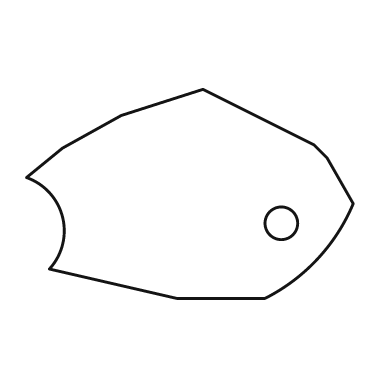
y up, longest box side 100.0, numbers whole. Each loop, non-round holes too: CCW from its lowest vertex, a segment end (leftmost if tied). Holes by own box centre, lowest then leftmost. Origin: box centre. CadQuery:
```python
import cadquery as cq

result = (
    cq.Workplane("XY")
    .moveTo(-4.0, -32.0)
    .lineTo(23.0, -32.0)
    .threePointArc((39.0, -20.0), (50.0, -3.0))
    .lineTo(42.0, 11.0)
    .lineTo(38.0, 15.0)
    .lineTo(4.0, 32.0)
    .lineTo(-21.0, 24.0)
    .lineTo(-39.0, 14.0)
    .lineTo(-50.0, 5.0)
    .threePointArc((-39.0, -7.0), (-43.0, -23.0))
    .close()
    .moveTo(28.0, -9.0)
    .circle(5.0)
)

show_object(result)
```